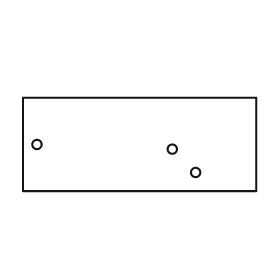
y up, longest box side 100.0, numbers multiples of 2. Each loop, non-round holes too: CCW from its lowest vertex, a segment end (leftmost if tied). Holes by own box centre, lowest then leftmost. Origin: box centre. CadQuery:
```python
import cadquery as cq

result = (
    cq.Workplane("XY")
    .moveTo(-50.0, -20.0)
    .lineTo(50.0, -20.0)
    .lineTo(50.0, 20.0)
    .lineTo(-50.0, 20.0)
    .close()
    .moveTo(24.0, -12.0)
    .circle(2.0)
    .moveTo(14.0, -2.0)
    .circle(2.0)
    .moveTo(-44.0, 0.0)
    .circle(2.0)
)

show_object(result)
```